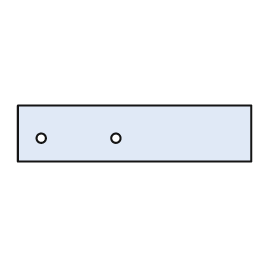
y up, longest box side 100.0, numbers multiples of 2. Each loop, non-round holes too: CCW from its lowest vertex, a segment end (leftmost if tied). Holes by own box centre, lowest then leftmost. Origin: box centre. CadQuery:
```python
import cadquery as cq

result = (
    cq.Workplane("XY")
    .moveTo(-50.0, -12.0)
    .lineTo(50.0, -12.0)
    .lineTo(50.0, 12.0)
    .lineTo(-50.0, 12.0)
    .close()
    .moveTo(-40.0, -2.0)
    .circle(2.0)
    .moveTo(-8.0, -2.0)
    .circle(2.0)
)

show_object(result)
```